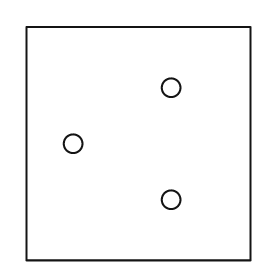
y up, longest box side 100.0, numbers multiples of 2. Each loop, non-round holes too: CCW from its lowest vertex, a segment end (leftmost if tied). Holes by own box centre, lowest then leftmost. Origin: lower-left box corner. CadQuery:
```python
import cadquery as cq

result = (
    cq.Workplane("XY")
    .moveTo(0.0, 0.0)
    .lineTo(96.0, 0.0)
    .lineTo(96.0, 100.0)
    .lineTo(0.0, 100.0)
    .close()
    .moveTo(62.0, 26.0)
    .circle(4.0)
    .moveTo(20.0, 50.0)
    .circle(4.0)
    .moveTo(62.0, 74.0)
    .circle(4.0)
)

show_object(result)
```